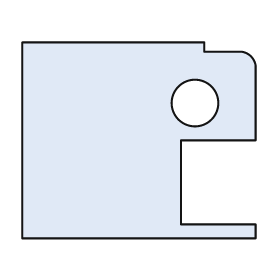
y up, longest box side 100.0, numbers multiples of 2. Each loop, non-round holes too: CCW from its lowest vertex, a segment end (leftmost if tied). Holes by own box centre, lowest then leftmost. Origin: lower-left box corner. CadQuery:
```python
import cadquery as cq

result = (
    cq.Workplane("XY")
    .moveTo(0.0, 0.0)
    .lineTo(100.0, 0.0)
    .lineTo(100.0, 6.0)
    .lineTo(68.0, 6.0)
    .lineTo(68.0, 42.0)
    .lineTo(100.0, 42.0)
    .lineTo(100.0, 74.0)
    .threePointArc((98.0, 78.0), (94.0, 80.0))
    .lineTo(78.0, 80.0)
    .lineTo(78.0, 84.0)
    .lineTo(0.0, 84.0)
    .close()
    .moveTo(74.0, 58.0)
    .circle(10.0)
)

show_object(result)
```